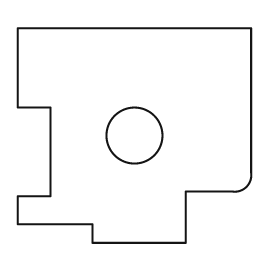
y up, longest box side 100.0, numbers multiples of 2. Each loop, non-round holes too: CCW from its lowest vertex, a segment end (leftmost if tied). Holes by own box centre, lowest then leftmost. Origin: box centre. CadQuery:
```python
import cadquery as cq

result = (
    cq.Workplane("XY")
    .moveTo(-18.0, -46.0)
    .lineTo(22.0, -46.0)
    .lineTo(22.0, -24.0)
    .lineTo(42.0, -24.0)
    .threePointArc((48.0, -22.0), (50.0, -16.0))
    .lineTo(50.0, 46.0)
    .lineTo(-50.0, 46.0)
    .lineTo(-50.0, 12.0)
    .lineTo(-36.0, 12.0)
    .lineTo(-36.0, -26.0)
    .lineTo(-50.0, -26.0)
    .lineTo(-50.0, -38.0)
    .lineTo(-18.0, -38.0)
    .close()
    .moveTo(0.0, 0.0)
    .circle(12.0)
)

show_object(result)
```